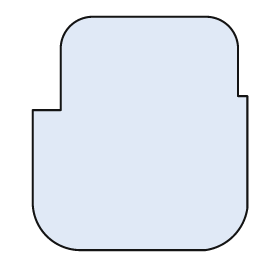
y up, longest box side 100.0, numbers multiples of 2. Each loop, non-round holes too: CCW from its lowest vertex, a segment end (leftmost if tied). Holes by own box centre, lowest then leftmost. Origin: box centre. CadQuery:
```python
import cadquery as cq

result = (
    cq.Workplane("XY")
    .moveTo(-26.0, -50.0)
    .lineTo(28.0, -50.0)
    .threePointArc((40.0, -44.0), (46.0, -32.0))
    .lineTo(46.0, 16.0)
    .lineTo(42.0, 16.0)
    .lineTo(42.0, 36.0)
    .threePointArc((38.0, 46.0), (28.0, 50.0))
    .lineTo(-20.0, 50.0)
    .threePointArc((-30.0, 46.0), (-34.0, 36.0))
    .lineTo(-34.0, 10.0)
    .lineTo(-46.0, 10.0)
    .lineTo(-46.0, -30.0)
    .threePointArc((-40.0, -44.0), (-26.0, -50.0))
    .close()
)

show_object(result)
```